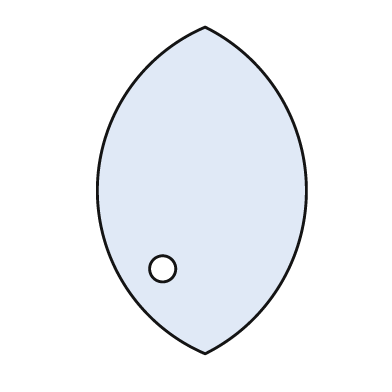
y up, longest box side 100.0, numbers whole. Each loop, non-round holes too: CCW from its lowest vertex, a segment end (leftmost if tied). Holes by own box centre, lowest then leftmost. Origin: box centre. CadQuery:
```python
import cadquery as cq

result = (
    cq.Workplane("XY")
    .moveTo(1.0, -50.0)
    .threePointArc((32.0, 0.0), (1.0, 50.0))
    .threePointArc((-32.0, 0.0), (1.0, -50.0))
    .close()
    .moveTo(-12.0, -24.0)
    .circle(4.0)
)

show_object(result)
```